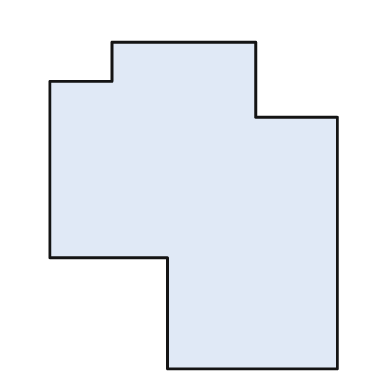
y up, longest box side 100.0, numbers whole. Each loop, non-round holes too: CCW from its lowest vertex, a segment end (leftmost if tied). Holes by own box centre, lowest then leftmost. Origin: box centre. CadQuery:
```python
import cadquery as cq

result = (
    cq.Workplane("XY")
    .moveTo(-8.0, -50.0)
    .lineTo(44.0, -50.0)
    .lineTo(44.0, 27.0)
    .lineTo(19.0, 27.0)
    .lineTo(19.0, 50.0)
    .lineTo(-25.0, 50.0)
    .lineTo(-25.0, 38.0)
    .lineTo(-44.0, 38.0)
    .lineTo(-44.0, -16.0)
    .lineTo(-8.0, -16.0)
    .close()
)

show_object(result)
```